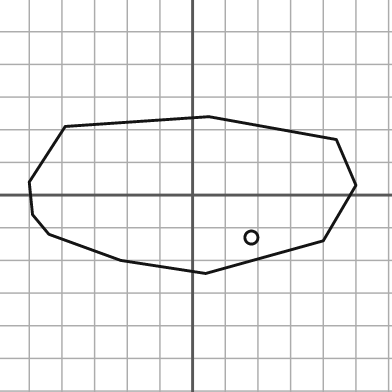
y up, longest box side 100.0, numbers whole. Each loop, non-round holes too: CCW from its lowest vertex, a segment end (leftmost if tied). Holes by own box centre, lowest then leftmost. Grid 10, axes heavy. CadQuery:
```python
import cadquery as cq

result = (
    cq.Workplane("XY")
    .moveTo(4.0, -24.0)
    .lineTo(40.0, -14.0)
    .lineTo(50.0, 3.0)
    .lineTo(44.0, 17.0)
    .lineTo(5.0, 24.0)
    .lineTo(-39.0, 21.0)
    .lineTo(-50.0, 4.0)
    .lineTo(-49.0, -6.0)
    .lineTo(-44.0, -12.0)
    .lineTo(-22.0, -20.0)
    .close()
    .moveTo(18.0, -13.0)
    .circle(2.0)
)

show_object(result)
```